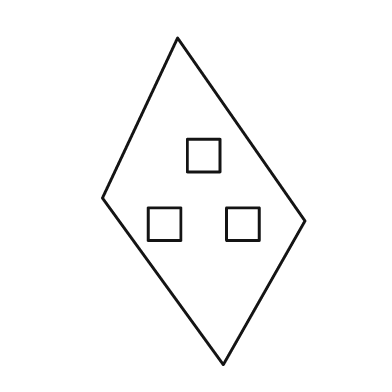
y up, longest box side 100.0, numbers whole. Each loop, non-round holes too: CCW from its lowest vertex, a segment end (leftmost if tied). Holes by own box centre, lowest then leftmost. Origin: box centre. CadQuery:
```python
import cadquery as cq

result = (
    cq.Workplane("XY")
    .moveTo(6.0, -50.0)
    .lineTo(31.0, -6.0)
    .lineTo(-8.0, 50.0)
    .lineTo(-31.0, 1.0)
    .close()
    .moveTo(-17.0, -12.0)
    .lineTo(-7.0, -12.0)
    .lineTo(-7.0, -2.0)
    .lineTo(-17.0, -2.0)
    .close()
    .moveTo(7.0, -12.0)
    .lineTo(17.0, -12.0)
    .lineTo(17.0, -2.0)
    .lineTo(7.0, -2.0)
    .close()
    .moveTo(-5.0, 9.0)
    .lineTo(5.0, 9.0)
    .lineTo(5.0, 19.0)
    .lineTo(-5.0, 19.0)
    .close()
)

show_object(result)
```